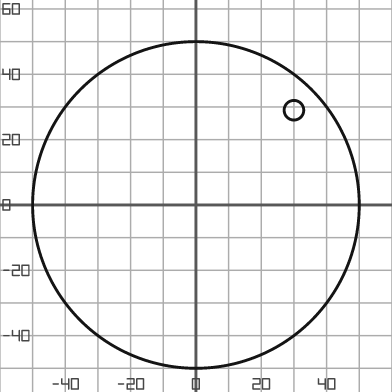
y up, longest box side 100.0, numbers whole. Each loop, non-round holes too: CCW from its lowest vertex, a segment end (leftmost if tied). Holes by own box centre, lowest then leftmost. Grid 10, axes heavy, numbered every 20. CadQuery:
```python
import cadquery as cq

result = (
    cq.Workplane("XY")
    .moveTo(0.0, 0.0)
    .circle(50.0)
    .moveTo(30.0, 29.0)
    .circle(3.0)
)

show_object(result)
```